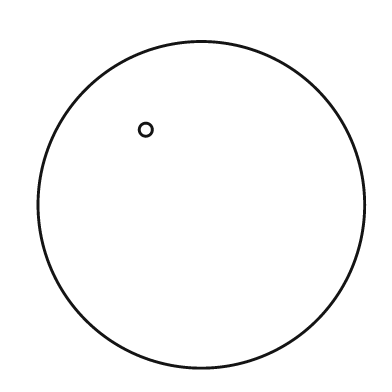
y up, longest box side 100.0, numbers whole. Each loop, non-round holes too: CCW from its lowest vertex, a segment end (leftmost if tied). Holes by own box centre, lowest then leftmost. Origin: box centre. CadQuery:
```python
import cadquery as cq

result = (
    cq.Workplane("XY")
    .moveTo(0.0, 0.0)
    .circle(50.0)
    .moveTo(-17.0, 23.0)
    .circle(2.0)
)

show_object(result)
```